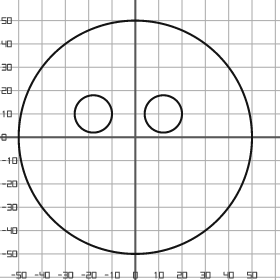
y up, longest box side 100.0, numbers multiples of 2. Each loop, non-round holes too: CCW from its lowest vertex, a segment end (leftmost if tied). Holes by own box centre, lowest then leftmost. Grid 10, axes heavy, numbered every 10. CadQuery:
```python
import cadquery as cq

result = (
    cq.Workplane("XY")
    .moveTo(0.0, 0.0)
    .circle(50.0)
    .moveTo(-18.0, 10.0)
    .circle(8.0)
    .moveTo(12.0, 10.0)
    .circle(8.0)
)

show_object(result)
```